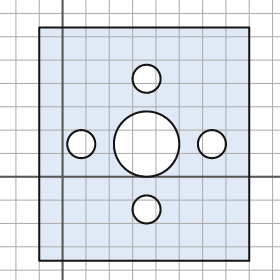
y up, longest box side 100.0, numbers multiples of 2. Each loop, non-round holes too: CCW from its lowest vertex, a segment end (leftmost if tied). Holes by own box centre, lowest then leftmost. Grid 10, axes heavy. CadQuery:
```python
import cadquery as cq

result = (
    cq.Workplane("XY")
    .moveTo(-10.0, -36.0)
    .lineTo(80.0, -36.0)
    .lineTo(80.0, 64.0)
    .lineTo(-10.0, 64.0)
    .close()
    .moveTo(36.0, -14.0)
    .circle(6.0)
    .moveTo(8.0, 14.0)
    .circle(6.0)
    .moveTo(36.0, 14.0)
    .circle(14.0)
    .moveTo(64.0, 14.0)
    .circle(6.0)
    .moveTo(36.0, 42.0)
    .circle(6.0)
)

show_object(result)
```